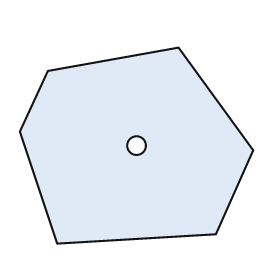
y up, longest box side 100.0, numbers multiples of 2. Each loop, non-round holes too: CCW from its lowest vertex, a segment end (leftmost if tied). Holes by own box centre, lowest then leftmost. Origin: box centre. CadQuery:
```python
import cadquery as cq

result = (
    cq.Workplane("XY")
    .moveTo(-34.0, -42.0)
    .lineTo(34.0, -38.0)
    .lineTo(50.0, -2.0)
    .lineTo(18.0, 42.0)
    .lineTo(-38.0, 32.0)
    .lineTo(-50.0, 6.0)
    .close()
    .moveTo(0.0, 0.0)
    .circle(4.0)
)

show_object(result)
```